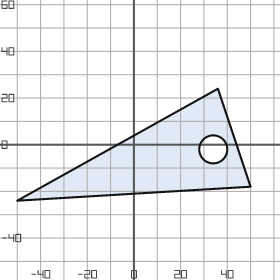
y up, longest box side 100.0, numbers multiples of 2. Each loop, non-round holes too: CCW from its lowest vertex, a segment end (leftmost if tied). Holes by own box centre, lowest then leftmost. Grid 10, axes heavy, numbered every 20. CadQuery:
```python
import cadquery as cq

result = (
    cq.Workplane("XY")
    .moveTo(-50.0, -24.0)
    .lineTo(50.0, -18.0)
    .lineTo(36.0, 24.0)
    .close()
    .moveTo(34.0, -2.0)
    .circle(6.0)
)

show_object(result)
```